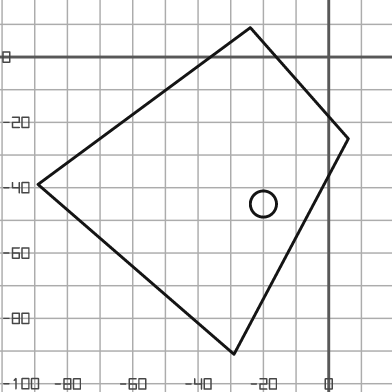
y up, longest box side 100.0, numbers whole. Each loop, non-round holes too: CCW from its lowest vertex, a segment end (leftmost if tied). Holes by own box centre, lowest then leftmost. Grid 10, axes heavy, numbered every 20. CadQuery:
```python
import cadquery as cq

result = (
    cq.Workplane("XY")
    .moveTo(-29.0, -91.0)
    .lineTo(6.0, -25.0)
    .lineTo(-24.0, 9.0)
    .lineTo(-89.0, -39.0)
    .close()
    .moveTo(-20.0, -45.0)
    .circle(4.0)
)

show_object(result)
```